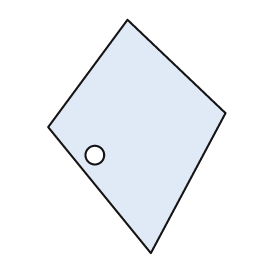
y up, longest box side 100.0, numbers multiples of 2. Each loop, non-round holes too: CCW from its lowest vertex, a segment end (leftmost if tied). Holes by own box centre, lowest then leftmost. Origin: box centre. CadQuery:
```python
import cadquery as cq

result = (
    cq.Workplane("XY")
    .moveTo(6.0, -50.0)
    .lineTo(38.0, 10.0)
    .lineTo(-4.0, 50.0)
    .lineTo(-38.0, 4.0)
    .close()
    .moveTo(-18.0, -8.0)
    .circle(4.0)
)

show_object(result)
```